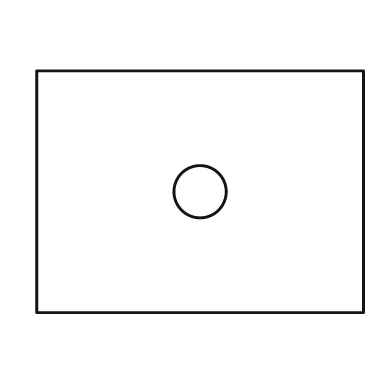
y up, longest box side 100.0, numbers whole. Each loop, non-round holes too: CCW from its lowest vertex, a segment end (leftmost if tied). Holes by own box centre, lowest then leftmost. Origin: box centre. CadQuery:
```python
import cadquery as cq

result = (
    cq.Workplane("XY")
    .moveTo(-50.0, -37.0)
    .lineTo(50.0, -37.0)
    .lineTo(50.0, 37.0)
    .lineTo(-50.0, 37.0)
    .close()
    .moveTo(0.0, 0.0)
    .circle(8.0)
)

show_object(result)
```